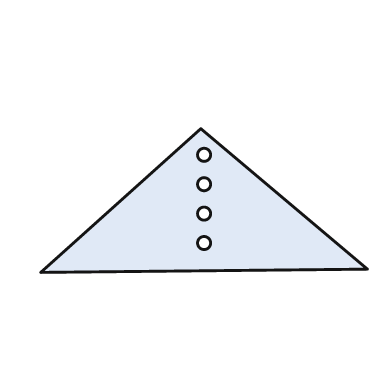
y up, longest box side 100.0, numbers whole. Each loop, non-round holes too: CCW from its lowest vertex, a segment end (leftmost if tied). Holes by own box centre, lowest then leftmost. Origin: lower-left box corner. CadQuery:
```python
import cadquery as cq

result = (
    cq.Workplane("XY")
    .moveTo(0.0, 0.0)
    .lineTo(100.0, 1.0)
    .lineTo(49.0, 44.0)
    .close()
    .moveTo(50.0, 9.0)
    .circle(2.0)
    .moveTo(50.0, 18.0)
    .circle(2.0)
    .moveTo(50.0, 27.0)
    .circle(2.0)
    .moveTo(50.0, 36.0)
    .circle(2.0)
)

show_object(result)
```